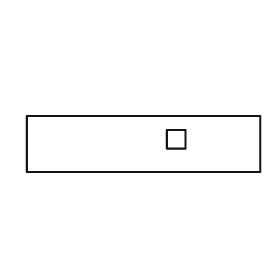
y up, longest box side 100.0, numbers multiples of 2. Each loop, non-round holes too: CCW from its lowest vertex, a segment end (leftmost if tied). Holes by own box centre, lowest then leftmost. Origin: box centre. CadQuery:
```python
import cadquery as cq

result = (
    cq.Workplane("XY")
    .moveTo(-50.0, -12.0)
    .lineTo(50.0, -12.0)
    .lineTo(50.0, 12.0)
    .lineTo(-50.0, 12.0)
    .close()
    .moveTo(10.0, -2.0)
    .lineTo(18.0, -2.0)
    .lineTo(18.0, 6.0)
    .lineTo(10.0, 6.0)
    .close()
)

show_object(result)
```